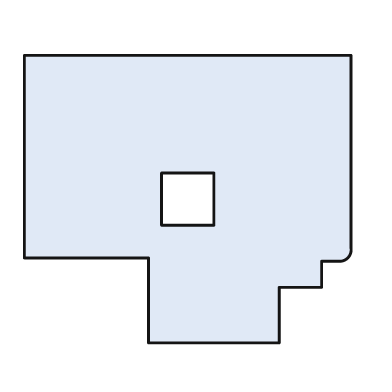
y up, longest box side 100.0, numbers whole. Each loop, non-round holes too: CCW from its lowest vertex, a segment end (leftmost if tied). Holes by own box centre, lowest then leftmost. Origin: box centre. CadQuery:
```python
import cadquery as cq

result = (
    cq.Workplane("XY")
    .moveTo(-12.0, -44.0)
    .lineTo(28.0, -44.0)
    .lineTo(28.0, -27.0)
    .lineTo(41.0, -27.0)
    .lineTo(41.0, -19.0)
    .lineTo(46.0, -19.0)
    .threePointArc((49.0, -18.0), (50.0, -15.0))
    .lineTo(50.0, 44.0)
    .lineTo(-50.0, 44.0)
    .lineTo(-50.0, -18.0)
    .lineTo(-12.0, -18.0)
    .close()
    .moveTo(-8.0, -8.0)
    .lineTo(8.0, -8.0)
    .lineTo(8.0, 8.0)
    .lineTo(-8.0, 8.0)
    .close()
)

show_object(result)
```